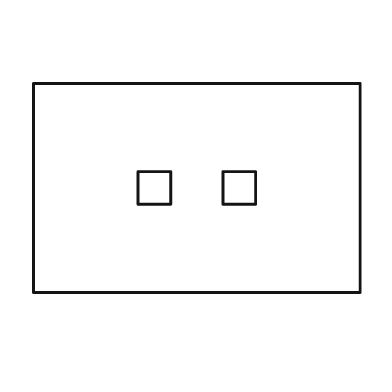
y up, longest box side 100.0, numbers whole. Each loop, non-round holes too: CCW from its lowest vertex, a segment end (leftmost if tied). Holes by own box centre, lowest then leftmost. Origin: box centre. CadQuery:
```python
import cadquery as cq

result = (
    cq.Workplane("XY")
    .moveTo(-50.0, -32.0)
    .lineTo(50.0, -32.0)
    .lineTo(50.0, 32.0)
    .lineTo(-50.0, 32.0)
    .close()
    .moveTo(-18.0, -5.0)
    .lineTo(-8.0, -5.0)
    .lineTo(-8.0, 5.0)
    .lineTo(-18.0, 5.0)
    .close()
    .moveTo(8.0, -5.0)
    .lineTo(18.0, -5.0)
    .lineTo(18.0, 5.0)
    .lineTo(8.0, 5.0)
    .close()
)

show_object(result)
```